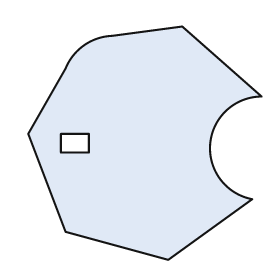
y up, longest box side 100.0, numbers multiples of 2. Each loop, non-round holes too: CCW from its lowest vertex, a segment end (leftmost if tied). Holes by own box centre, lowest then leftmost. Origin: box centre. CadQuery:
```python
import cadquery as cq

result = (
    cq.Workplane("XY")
    .moveTo(10.0, -50.0)
    .lineTo(46.0, -24.0)
    .threePointArc((28.0, 0.0), (50.0, 20.0))
    .lineTo(16.0, 50.0)
    .lineTo(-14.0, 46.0)
    .threePointArc((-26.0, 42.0), (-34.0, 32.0))
    .lineTo(-50.0, 4.0)
    .lineTo(-34.0, -38.0)
    .close()
    .moveTo(-36.0, -4.0)
    .lineTo(-24.0, -4.0)
    .lineTo(-24.0, 4.0)
    .lineTo(-36.0, 4.0)
    .close()
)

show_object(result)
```